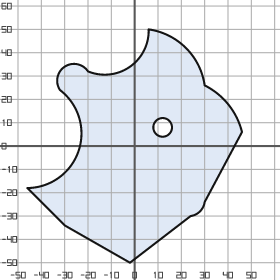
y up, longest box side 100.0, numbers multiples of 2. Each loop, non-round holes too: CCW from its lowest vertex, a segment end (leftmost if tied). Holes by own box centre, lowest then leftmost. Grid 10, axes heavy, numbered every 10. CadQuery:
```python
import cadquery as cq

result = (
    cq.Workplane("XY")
    .moveTo(-2.0, -50.0)
    .lineTo(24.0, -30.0)
    .threePointArc((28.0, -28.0), (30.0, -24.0))
    .lineTo(46.0, 6.0)
    .threePointArc((40.0, 18.0), (30.0, 26.0))
    .threePointArc((22.0, 42.0), (6.0, 50.0))
    .threePointArc((-2.0, 34.0), (-20.0, 32.0))
    .threePointArc((-30.0, 34.0), (-32.0, 24.0))
    .threePointArc((-24.0, -2.0), (-46.0, -18.0))
    .lineTo(-30.0, -34.0)
    .close()
    .moveTo(12.0, 8.0)
    .circle(4.0)
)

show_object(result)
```